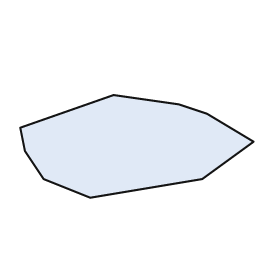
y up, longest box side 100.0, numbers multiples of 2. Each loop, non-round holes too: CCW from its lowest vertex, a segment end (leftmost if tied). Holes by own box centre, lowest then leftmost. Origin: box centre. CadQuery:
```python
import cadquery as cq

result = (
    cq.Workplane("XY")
    .moveTo(-20.0, -22.0)
    .lineTo(28.0, -14.0)
    .lineTo(50.0, 2.0)
    .lineTo(30.0, 14.0)
    .lineTo(18.0, 18.0)
    .lineTo(-10.0, 22.0)
    .lineTo(-50.0, 8.0)
    .lineTo(-48.0, -2.0)
    .lineTo(-40.0, -14.0)
    .close()
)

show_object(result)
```